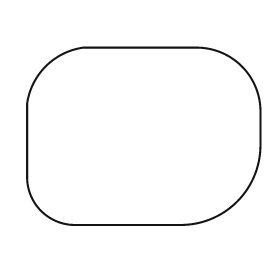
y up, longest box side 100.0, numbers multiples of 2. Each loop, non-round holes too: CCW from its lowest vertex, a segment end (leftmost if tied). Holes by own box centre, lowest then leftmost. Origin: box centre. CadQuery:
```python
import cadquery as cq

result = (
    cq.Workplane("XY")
    .moveTo(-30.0, -38.0)
    .lineTo(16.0, -38.0)
    .threePointArc((40.0, -28.0), (50.0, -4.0))
    .lineTo(50.0, 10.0)
    .threePointArc((42.0, 30.0), (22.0, 38.0))
    .lineTo(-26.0, 38.0)
    .threePointArc((-42.0, 30.0), (-50.0, 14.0))
    .lineTo(-50.0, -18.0)
    .threePointArc((-44.0, -32.0), (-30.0, -38.0))
    .close()
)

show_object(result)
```